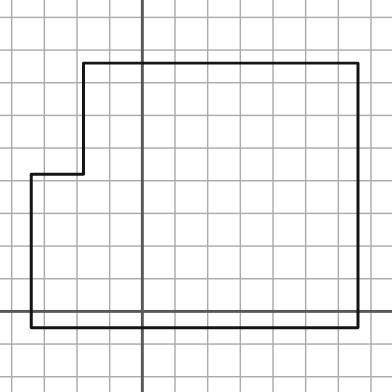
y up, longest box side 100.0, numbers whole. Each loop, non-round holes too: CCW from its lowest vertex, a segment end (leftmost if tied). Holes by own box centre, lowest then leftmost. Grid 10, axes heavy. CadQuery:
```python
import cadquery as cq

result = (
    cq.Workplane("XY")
    .moveTo(-34.0, -5.0)
    .lineTo(66.0, -5.0)
    .lineTo(66.0, 76.0)
    .lineTo(-18.0, 76.0)
    .lineTo(-18.0, 42.0)
    .lineTo(-34.0, 42.0)
    .close()
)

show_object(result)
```